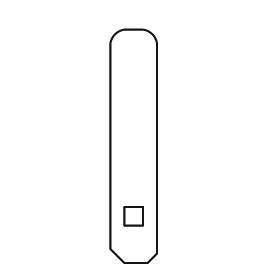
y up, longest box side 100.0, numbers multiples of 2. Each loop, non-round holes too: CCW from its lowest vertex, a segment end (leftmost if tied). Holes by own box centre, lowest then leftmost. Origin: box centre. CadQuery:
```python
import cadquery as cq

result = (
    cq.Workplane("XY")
    .moveTo(-4.0, -50.0)
    .lineTo(6.0, -50.0)
    .lineTo(10.0, -46.0)
    .lineTo(10.0, 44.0)
    .threePointArc((8.0, 48.0), (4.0, 50.0))
    .lineTo(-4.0, 50.0)
    .threePointArc((-8.0, 48.0), (-10.0, 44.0))
    .lineTo(-10.0, -44.0)
    .close()
    .moveTo(-4.0, -34.0)
    .lineTo(4.0, -34.0)
    .lineTo(4.0, -26.0)
    .lineTo(-4.0, -26.0)
    .close()
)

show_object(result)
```